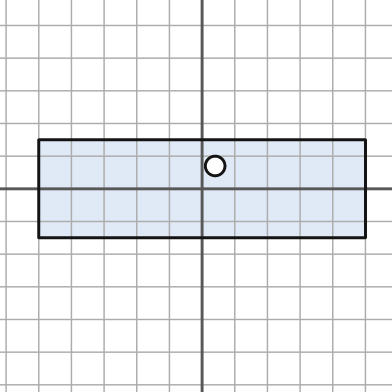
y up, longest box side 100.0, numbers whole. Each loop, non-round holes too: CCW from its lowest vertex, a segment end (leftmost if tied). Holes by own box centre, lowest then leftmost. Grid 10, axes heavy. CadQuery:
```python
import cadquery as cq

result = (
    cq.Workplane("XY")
    .moveTo(-50.0, -15.0)
    .lineTo(50.0, -15.0)
    .lineTo(50.0, 15.0)
    .lineTo(-50.0, 15.0)
    .close()
    .moveTo(4.0, 7.0)
    .circle(3.0)
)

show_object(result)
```